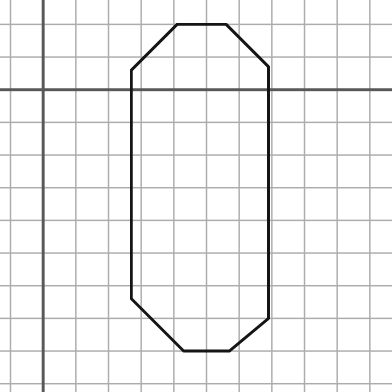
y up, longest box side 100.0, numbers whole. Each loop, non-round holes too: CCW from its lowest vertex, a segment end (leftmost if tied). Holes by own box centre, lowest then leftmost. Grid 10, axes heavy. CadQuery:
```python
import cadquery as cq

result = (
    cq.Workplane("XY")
    .moveTo(43.0, -80.0)
    .lineTo(57.0, -80.0)
    .lineTo(69.0, -70.0)
    .lineTo(69.0, 7.0)
    .lineTo(56.0, 20.0)
    .lineTo(41.0, 20.0)
    .lineTo(27.0, 6.0)
    .lineTo(27.0, -64.0)
    .close()
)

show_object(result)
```